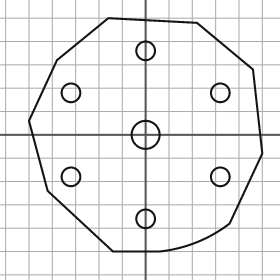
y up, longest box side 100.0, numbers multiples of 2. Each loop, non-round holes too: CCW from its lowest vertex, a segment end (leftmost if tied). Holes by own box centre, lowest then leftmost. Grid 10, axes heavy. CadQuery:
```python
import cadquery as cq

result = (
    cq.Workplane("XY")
    .moveTo(-14.0, -50.0)
    .lineTo(6.0, -50.0)
    .threePointArc((22.0, -46.0), (36.0, -38.0))
    .lineTo(50.0, -8.0)
    .lineTo(46.0, 28.0)
    .lineTo(22.0, 48.0)
    .lineTo(-16.0, 50.0)
    .lineTo(-38.0, 32.0)
    .lineTo(-50.0, 6.0)
    .lineTo(-42.0, -24.0)
    .close()
    .moveTo(0.0, -36.0)
    .circle(4.0)
    .moveTo(-32.0, -18.0)
    .circle(4.0)
    .moveTo(32.0, -18.0)
    .circle(4.0)
    .moveTo(0.0, 0.0)
    .circle(6.0)
    .moveTo(-32.0, 18.0)
    .circle(4.0)
    .moveTo(32.0, 18.0)
    .circle(4.0)
    .moveTo(0.0, 36.0)
    .circle(4.0)
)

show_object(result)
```